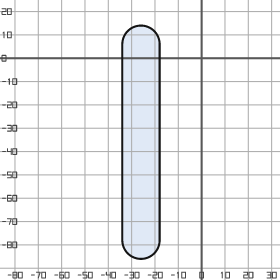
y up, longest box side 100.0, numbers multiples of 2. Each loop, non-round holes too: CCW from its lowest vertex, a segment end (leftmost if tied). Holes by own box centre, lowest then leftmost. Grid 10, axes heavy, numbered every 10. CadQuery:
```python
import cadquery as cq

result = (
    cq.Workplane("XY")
    .moveTo(-34.0, -78.0)
    .threePointArc((-26.0, -86.0), (-18.0, -78.0))
    .lineTo(-18.0, 6.0)
    .threePointArc((-26.0, 14.0), (-34.0, 6.0))
    .close()
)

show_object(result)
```